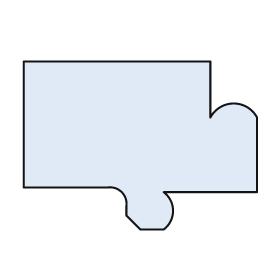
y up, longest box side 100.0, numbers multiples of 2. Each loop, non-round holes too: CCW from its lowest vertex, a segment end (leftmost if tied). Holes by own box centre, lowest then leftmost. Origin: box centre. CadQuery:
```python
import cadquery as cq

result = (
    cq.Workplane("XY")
    .moveTo(0.0, -36.0)
    .lineTo(10.0, -36.0)
    .threePointArc((14.0, -28.0), (10.0, -20.0))
    .lineTo(50.0, -20.0)
    .lineTo(50.0, 12.0)
    .threePointArc((40.0, 18.0), (30.0, 12.0))
    .lineTo(30.0, 36.0)
    .lineTo(-50.0, 36.0)
    .lineTo(-50.0, -18.0)
    .lineTo(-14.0, -18.0)
    .threePointArc((-8.0, -20.0), (-6.0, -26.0))
    .lineTo(-6.0, -30.0)
    .close()
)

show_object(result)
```